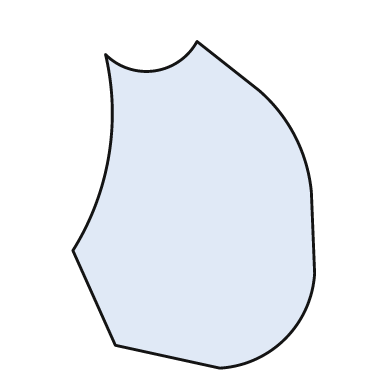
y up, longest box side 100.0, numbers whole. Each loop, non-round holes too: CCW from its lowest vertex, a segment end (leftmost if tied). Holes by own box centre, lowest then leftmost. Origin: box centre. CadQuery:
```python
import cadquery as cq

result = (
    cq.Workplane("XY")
    .moveTo(8.0, -50.0)
    .threePointArc((28.0, -41.0), (37.0, -21.0))
    .lineTo(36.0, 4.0)
    .threePointArc((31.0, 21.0), (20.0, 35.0))
    .lineTo(1.0, 50.0)
    .threePointArc((-12.0, 41.0), (-27.0, 46.0))
    .threePointArc((-26.0, 15.0), (-37.0, -14.0))
    .lineTo(-24.0, -43.0)
    .close()
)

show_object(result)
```